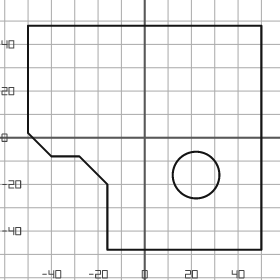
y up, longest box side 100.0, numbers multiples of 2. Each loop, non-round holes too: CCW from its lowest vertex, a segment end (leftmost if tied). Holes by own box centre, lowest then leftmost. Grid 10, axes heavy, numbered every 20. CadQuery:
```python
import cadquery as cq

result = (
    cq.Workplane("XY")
    .moveTo(-16.0, -48.0)
    .lineTo(50.0, -48.0)
    .lineTo(50.0, 48.0)
    .lineTo(-50.0, 48.0)
    .lineTo(-50.0, 2.0)
    .lineTo(-40.0, -8.0)
    .lineTo(-28.0, -8.0)
    .lineTo(-16.0, -20.0)
    .close()
    .moveTo(22.0, -16.0)
    .circle(10.0)
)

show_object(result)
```